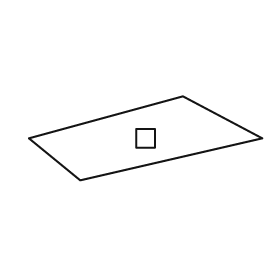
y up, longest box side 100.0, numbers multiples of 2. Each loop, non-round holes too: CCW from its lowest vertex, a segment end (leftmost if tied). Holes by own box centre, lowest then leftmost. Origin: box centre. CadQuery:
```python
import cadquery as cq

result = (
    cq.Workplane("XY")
    .moveTo(-28.0, -18.0)
    .lineTo(50.0, 0.0)
    .lineTo(16.0, 18.0)
    .lineTo(-50.0, 0.0)
    .close()
    .moveTo(-4.0, -4.0)
    .lineTo(4.0, -4.0)
    .lineTo(4.0, 4.0)
    .lineTo(-4.0, 4.0)
    .close()
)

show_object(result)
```